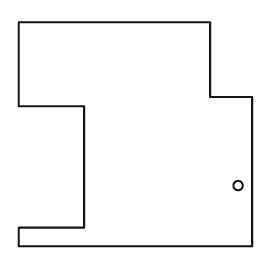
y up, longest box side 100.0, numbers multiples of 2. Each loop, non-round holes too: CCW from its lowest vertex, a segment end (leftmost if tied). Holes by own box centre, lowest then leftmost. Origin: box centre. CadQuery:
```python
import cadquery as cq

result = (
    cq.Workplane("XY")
    .moveTo(-50.0, -48.0)
    .lineTo(50.0, -48.0)
    .lineTo(50.0, 16.0)
    .lineTo(32.0, 16.0)
    .lineTo(32.0, 48.0)
    .lineTo(-50.0, 48.0)
    .lineTo(-50.0, 12.0)
    .lineTo(-22.0, 12.0)
    .lineTo(-22.0, -40.0)
    .lineTo(-50.0, -40.0)
    .close()
    .moveTo(44.0, -22.0)
    .circle(2.0)
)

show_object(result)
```